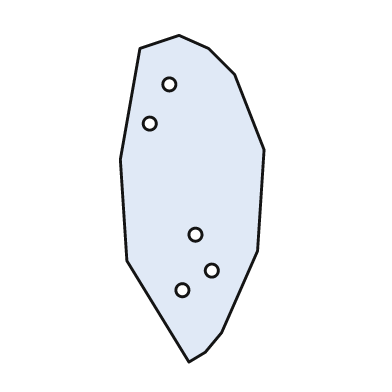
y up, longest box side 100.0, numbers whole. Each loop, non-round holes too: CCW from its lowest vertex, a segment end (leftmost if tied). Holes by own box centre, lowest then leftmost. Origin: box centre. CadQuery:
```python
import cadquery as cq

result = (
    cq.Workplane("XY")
    .moveTo(-1.0, -50.0)
    .lineTo(4.0, -47.0)
    .lineTo(9.0, -41.0)
    .lineTo(20.0, -16.0)
    .lineTo(22.0, 15.0)
    .lineTo(13.0, 38.0)
    .lineTo(5.0, 46.0)
    .lineTo(-4.0, 50.0)
    .lineTo(-16.0, 46.0)
    .lineTo(-22.0, 12.0)
    .lineTo(-20.0, -19.0)
    .close()
    .moveTo(-3.0, -28.0)
    .circle(2.0)
    .moveTo(6.0, -22.0)
    .circle(2.0)
    .moveTo(1.0, -11.0)
    .circle(2.0)
    .moveTo(-13.0, 23.0)
    .circle(2.0)
    .moveTo(-7.0, 35.0)
    .circle(2.0)
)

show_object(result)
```